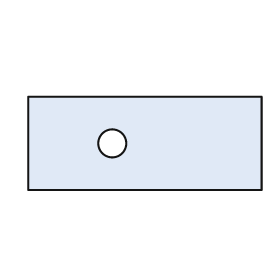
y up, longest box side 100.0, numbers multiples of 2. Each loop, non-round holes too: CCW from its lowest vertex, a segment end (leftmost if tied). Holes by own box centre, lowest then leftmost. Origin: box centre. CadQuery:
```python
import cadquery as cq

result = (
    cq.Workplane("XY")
    .moveTo(-50.0, -20.0)
    .lineTo(50.0, -20.0)
    .lineTo(50.0, 20.0)
    .lineTo(-50.0, 20.0)
    .close()
    .moveTo(-14.0, 0.0)
    .circle(6.0)
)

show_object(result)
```